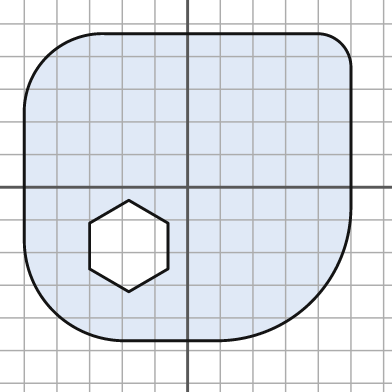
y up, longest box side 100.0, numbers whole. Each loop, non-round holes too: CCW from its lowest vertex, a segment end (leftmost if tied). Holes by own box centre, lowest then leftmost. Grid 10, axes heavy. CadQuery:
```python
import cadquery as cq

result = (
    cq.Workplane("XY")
    .moveTo(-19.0, -47.0)
    .lineTo(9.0, -47.0)
    .threePointArc((38.0, -35.0), (50.0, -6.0))
    .lineTo(50.0, 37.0)
    .threePointArc((47.0, 44.0), (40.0, 47.0))
    .lineTo(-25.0, 47.0)
    .threePointArc((-43.0, 40.0), (-50.0, 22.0))
    .lineTo(-50.0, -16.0)
    .threePointArc((-41.0, -38.0), (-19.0, -47.0))
    .close()
    .moveTo(-18.0, -32.0)
    .lineTo(-6.0, -25.0)
    .lineTo(-6.0, -11.0)
    .lineTo(-18.0, -4.0)
    .lineTo(-30.0, -11.0)
    .lineTo(-30.0, -25.0)
    .close()
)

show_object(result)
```